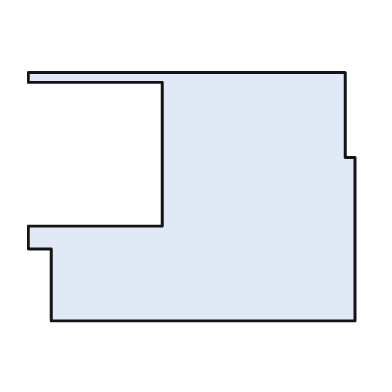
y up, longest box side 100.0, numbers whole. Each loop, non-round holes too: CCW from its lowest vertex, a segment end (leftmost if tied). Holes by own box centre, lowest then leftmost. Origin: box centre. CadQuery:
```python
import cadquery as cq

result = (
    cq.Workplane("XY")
    .moveTo(-43.0, -38.0)
    .lineTo(50.0, -38.0)
    .lineTo(50.0, 12.0)
    .lineTo(47.0, 12.0)
    .lineTo(47.0, 38.0)
    .lineTo(-50.0, 38.0)
    .lineTo(-50.0, 35.0)
    .lineTo(-9.0, 35.0)
    .lineTo(-9.0, -9.0)
    .lineTo(-50.0, -9.0)
    .lineTo(-50.0, -16.0)
    .lineTo(-43.0, -16.0)
    .close()
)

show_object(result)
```